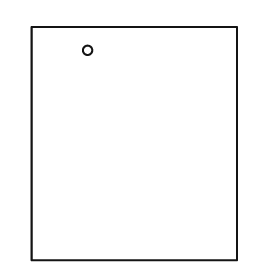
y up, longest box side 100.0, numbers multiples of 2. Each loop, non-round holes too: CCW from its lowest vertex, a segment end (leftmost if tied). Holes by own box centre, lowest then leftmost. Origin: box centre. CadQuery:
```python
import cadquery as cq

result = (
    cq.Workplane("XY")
    .moveTo(-44.0, -50.0)
    .lineTo(44.0, -50.0)
    .lineTo(44.0, 50.0)
    .lineTo(-44.0, 50.0)
    .close()
    .moveTo(-20.0, 40.0)
    .circle(2.0)
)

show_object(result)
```